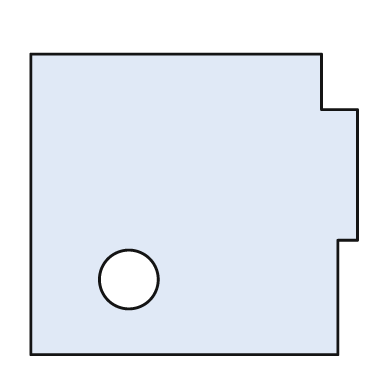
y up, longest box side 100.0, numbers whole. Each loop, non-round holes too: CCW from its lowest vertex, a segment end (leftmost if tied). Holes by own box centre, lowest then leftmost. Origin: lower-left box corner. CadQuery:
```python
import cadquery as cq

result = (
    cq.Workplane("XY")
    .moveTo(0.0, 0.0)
    .lineTo(94.0, 0.0)
    .lineTo(94.0, 35.0)
    .lineTo(100.0, 35.0)
    .lineTo(100.0, 75.0)
    .lineTo(89.0, 75.0)
    .lineTo(89.0, 92.0)
    .lineTo(0.0, 92.0)
    .close()
    .moveTo(30.0, 23.0)
    .circle(9.0)
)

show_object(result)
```